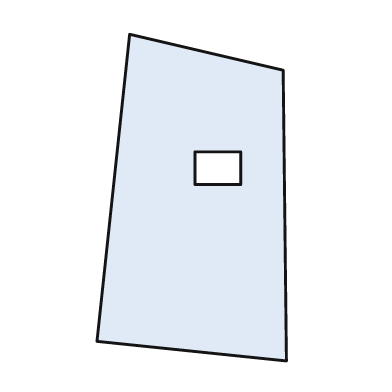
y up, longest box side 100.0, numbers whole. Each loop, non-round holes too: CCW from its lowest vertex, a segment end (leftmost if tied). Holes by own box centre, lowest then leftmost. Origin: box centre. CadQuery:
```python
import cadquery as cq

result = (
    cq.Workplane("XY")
    .moveTo(29.0, -50.0)
    .lineTo(28.0, 39.0)
    .lineTo(-19.0, 50.0)
    .lineTo(-29.0, -44.0)
    .close()
    .moveTo(1.0, 4.0)
    .lineTo(15.0, 4.0)
    .lineTo(15.0, 14.0)
    .lineTo(1.0, 14.0)
    .close()
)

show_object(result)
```